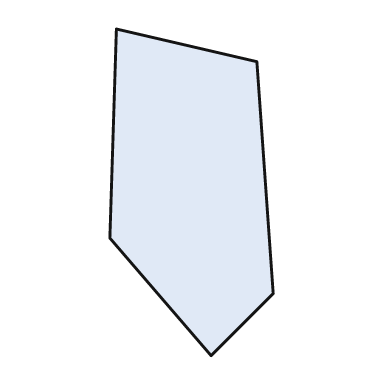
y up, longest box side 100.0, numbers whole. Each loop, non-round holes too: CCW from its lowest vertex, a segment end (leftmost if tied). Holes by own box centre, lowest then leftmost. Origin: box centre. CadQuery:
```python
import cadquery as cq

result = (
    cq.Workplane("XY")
    .moveTo(6.0, -50.0)
    .lineTo(25.0, -31.0)
    .lineTo(20.0, 40.0)
    .lineTo(-23.0, 50.0)
    .lineTo(-25.0, -14.0)
    .close()
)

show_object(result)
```